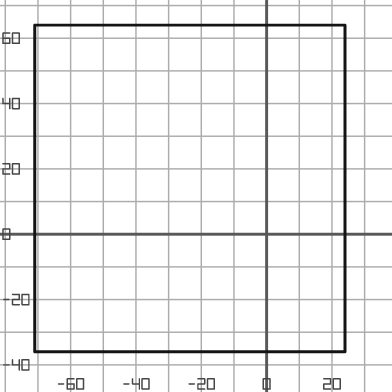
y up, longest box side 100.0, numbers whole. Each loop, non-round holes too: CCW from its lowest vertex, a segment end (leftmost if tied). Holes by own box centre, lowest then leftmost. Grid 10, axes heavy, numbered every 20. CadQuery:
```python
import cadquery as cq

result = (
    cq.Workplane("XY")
    .moveTo(-71.0, -36.0)
    .lineTo(24.0, -36.0)
    .lineTo(24.0, 64.0)
    .lineTo(-71.0, 64.0)
    .close()
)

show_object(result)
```